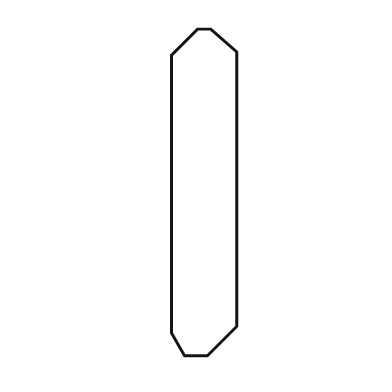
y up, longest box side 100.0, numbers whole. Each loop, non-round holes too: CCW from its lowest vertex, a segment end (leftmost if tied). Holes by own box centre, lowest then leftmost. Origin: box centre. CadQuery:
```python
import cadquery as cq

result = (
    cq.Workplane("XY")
    .moveTo(-6.0, -50.0)
    .lineTo(1.0, -50.0)
    .lineTo(10.0, -41.0)
    .lineTo(10.0, 43.0)
    .lineTo(2.0, 50.0)
    .lineTo(-2.0, 50.0)
    .lineTo(-10.0, 42.0)
    .lineTo(-10.0, -43.0)
    .close()
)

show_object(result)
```